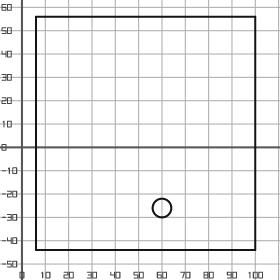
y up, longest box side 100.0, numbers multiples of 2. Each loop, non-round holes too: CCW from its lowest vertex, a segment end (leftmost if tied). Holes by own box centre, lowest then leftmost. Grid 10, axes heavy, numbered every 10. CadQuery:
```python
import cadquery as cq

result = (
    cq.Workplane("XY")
    .moveTo(6.0, -44.0)
    .lineTo(100.0, -44.0)
    .lineTo(100.0, 56.0)
    .lineTo(6.0, 56.0)
    .close()
    .moveTo(60.0, -26.0)
    .circle(4.0)
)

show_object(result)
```